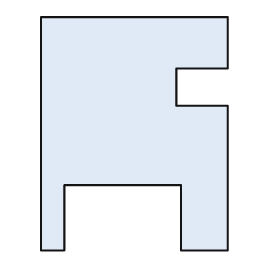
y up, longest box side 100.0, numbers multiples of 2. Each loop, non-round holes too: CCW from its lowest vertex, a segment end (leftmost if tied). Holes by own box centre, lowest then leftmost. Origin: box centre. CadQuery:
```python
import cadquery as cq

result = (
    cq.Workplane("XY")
    .moveTo(-40.0, -50.0)
    .lineTo(-30.0, -50.0)
    .lineTo(-30.0, -22.0)
    .lineTo(20.0, -22.0)
    .lineTo(20.0, -50.0)
    .lineTo(40.0, -50.0)
    .lineTo(40.0, 12.0)
    .lineTo(18.0, 12.0)
    .lineTo(18.0, 28.0)
    .lineTo(40.0, 28.0)
    .lineTo(40.0, 50.0)
    .lineTo(-40.0, 50.0)
    .close()
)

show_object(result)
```